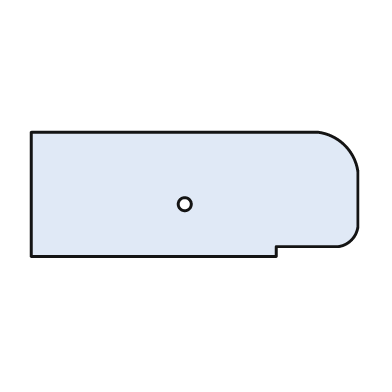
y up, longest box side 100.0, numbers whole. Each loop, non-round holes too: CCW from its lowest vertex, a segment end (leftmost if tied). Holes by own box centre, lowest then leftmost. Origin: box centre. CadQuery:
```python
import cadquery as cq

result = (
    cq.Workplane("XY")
    .moveTo(-50.0, -19.0)
    .lineTo(25.0, -19.0)
    .lineTo(25.0, -16.0)
    .lineTo(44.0, -16.0)
    .threePointArc((48.0, -14.0), (50.0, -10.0))
    .lineTo(50.0, 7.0)
    .threePointArc((46.0, 15.0), (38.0, 19.0))
    .lineTo(-50.0, 19.0)
    .close()
    .moveTo(-3.0, -3.0)
    .circle(2.0)
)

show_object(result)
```